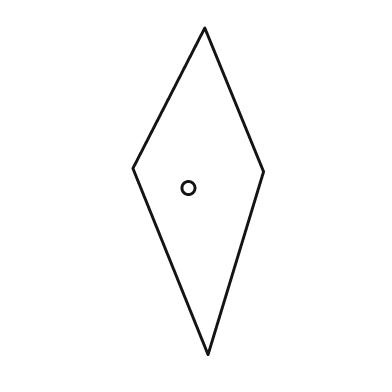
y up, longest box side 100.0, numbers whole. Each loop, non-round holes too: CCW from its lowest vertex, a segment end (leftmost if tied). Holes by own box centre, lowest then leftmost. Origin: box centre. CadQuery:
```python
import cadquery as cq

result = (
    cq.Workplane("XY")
    .moveTo(3.0, -50.0)
    .lineTo(20.0, 6.0)
    .lineTo(2.0, 50.0)
    .lineTo(-20.0, 7.0)
    .close()
    .moveTo(-3.0, 1.0)
    .circle(2.0)
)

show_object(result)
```